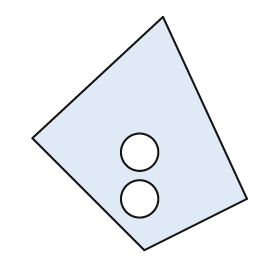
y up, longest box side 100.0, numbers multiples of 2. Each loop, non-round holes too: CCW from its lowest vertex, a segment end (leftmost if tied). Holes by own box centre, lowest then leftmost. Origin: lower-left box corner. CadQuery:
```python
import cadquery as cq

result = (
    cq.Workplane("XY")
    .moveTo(48.0, 0.0)
    .lineTo(92.0, 22.0)
    .lineTo(56.0, 100.0)
    .lineTo(0.0, 48.0)
    .close()
    .moveTo(46.0, 22.0)
    .circle(8.0)
    .moveTo(46.0, 42.0)
    .circle(8.0)
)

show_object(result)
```